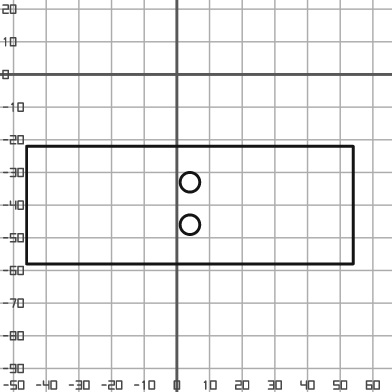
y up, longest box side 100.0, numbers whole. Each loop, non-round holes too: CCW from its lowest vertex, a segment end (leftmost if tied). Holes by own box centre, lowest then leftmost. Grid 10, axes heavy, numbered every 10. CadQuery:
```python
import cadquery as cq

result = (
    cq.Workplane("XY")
    .moveTo(-46.0, -58.0)
    .lineTo(54.0, -58.0)
    .lineTo(54.0, -22.0)
    .lineTo(-46.0, -22.0)
    .close()
    .moveTo(4.0, -46.0)
    .circle(3.0)
    .moveTo(4.0, -33.0)
    .circle(3.0)
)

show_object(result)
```